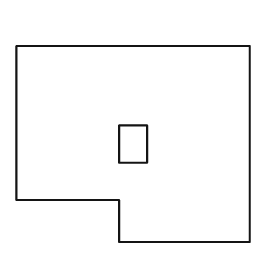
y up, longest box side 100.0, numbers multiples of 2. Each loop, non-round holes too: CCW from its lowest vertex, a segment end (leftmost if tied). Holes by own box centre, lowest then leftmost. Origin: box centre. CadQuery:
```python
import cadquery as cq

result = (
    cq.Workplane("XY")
    .moveTo(-6.0, -42.0)
    .lineTo(50.0, -42.0)
    .lineTo(50.0, 42.0)
    .lineTo(-50.0, 42.0)
    .lineTo(-50.0, -24.0)
    .lineTo(-6.0, -24.0)
    .close()
    .moveTo(-6.0, -8.0)
    .lineTo(6.0, -8.0)
    .lineTo(6.0, 8.0)
    .lineTo(-6.0, 8.0)
    .close()
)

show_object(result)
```